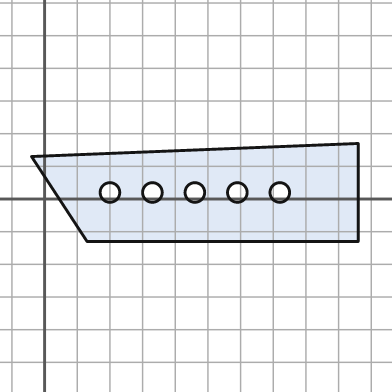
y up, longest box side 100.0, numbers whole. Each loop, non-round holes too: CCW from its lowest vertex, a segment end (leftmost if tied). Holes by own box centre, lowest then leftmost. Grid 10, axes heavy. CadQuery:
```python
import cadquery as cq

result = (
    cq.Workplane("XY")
    .moveTo(13.0, -13.0)
    .lineTo(96.0, -13.0)
    .lineTo(96.0, 17.0)
    .lineTo(-4.0, 13.0)
    .close()
    .moveTo(20.0, 2.0)
    .circle(3.0)
    .moveTo(33.0, 2.0)
    .circle(3.0)
    .moveTo(46.0, 2.0)
    .circle(3.0)
    .moveTo(59.0, 2.0)
    .circle(3.0)
    .moveTo(72.0, 2.0)
    .circle(3.0)
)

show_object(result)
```